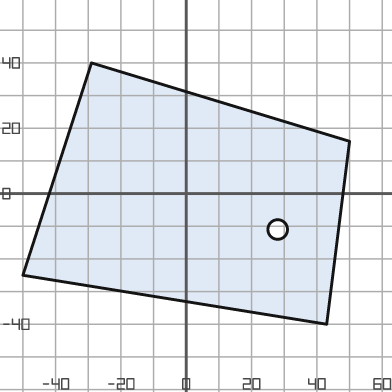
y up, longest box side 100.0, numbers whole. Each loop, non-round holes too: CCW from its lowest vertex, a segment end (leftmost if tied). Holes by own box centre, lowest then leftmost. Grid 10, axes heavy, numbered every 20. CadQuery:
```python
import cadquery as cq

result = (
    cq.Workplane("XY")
    .moveTo(43.0, -40.0)
    .lineTo(50.0, 16.0)
    .lineTo(-29.0, 40.0)
    .lineTo(-50.0, -25.0)
    .close()
    .moveTo(28.0, -11.0)
    .circle(3.0)
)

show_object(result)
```